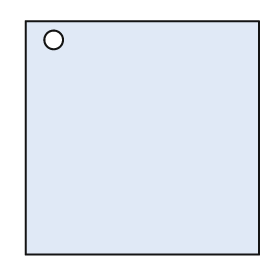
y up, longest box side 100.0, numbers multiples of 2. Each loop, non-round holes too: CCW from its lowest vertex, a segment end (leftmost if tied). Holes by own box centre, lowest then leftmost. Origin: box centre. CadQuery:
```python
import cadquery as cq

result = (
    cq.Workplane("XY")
    .moveTo(-50.0, -50.0)
    .lineTo(50.0, -50.0)
    .lineTo(50.0, 50.0)
    .lineTo(-50.0, 50.0)
    .close()
    .moveTo(-38.0, 42.0)
    .circle(4.0)
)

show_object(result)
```